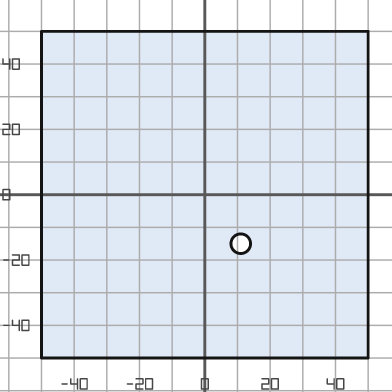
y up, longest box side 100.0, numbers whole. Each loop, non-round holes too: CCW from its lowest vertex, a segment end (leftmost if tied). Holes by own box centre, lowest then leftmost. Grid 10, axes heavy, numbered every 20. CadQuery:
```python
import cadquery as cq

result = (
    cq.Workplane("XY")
    .moveTo(-50.0, -50.0)
    .lineTo(50.0, -50.0)
    .lineTo(50.0, 50.0)
    .lineTo(-50.0, 50.0)
    .close()
    .moveTo(11.0, -15.0)
    .circle(3.0)
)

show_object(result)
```